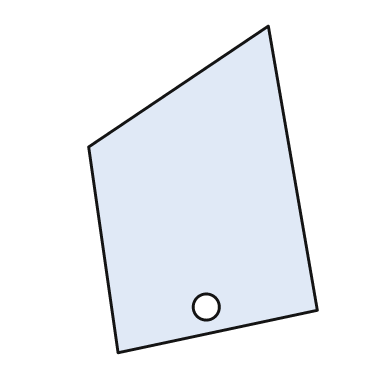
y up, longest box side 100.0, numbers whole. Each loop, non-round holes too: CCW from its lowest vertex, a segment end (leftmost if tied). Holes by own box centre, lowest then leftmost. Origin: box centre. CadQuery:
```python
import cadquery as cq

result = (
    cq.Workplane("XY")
    .moveTo(-26.0, -50.0)
    .lineTo(35.0, -37.0)
    .lineTo(20.0, 50.0)
    .lineTo(-35.0, 13.0)
    .close()
    .moveTo(1.0, -36.0)
    .circle(4.0)
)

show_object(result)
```